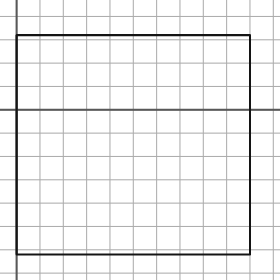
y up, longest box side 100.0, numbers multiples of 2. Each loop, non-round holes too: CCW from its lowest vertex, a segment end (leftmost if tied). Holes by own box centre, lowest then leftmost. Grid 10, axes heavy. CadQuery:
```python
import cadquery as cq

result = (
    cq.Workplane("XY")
    .moveTo(0.0, -62.0)
    .lineTo(100.0, -62.0)
    .lineTo(100.0, 32.0)
    .lineTo(0.0, 32.0)
    .close()
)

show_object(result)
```